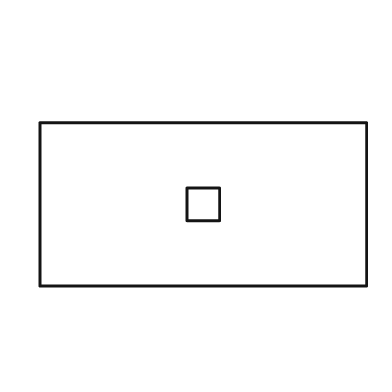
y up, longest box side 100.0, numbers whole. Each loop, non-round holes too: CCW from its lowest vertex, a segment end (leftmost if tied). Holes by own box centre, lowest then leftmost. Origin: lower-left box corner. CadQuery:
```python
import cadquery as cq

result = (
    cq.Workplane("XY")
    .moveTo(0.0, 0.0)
    .lineTo(100.0, 0.0)
    .lineTo(100.0, 50.0)
    .lineTo(0.0, 50.0)
    .close()
    .moveTo(45.0, 20.0)
    .lineTo(55.0, 20.0)
    .lineTo(55.0, 30.0)
    .lineTo(45.0, 30.0)
    .close()
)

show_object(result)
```